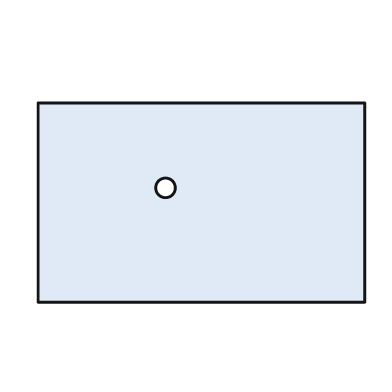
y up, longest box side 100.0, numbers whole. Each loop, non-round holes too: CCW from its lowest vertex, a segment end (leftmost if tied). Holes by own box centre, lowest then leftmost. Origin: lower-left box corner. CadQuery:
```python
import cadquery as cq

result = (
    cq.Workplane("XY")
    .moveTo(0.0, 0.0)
    .lineTo(100.0, 0.0)
    .lineTo(100.0, 61.0)
    .lineTo(0.0, 61.0)
    .close()
    .moveTo(39.0, 35.0)
    .circle(3.0)
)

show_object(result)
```